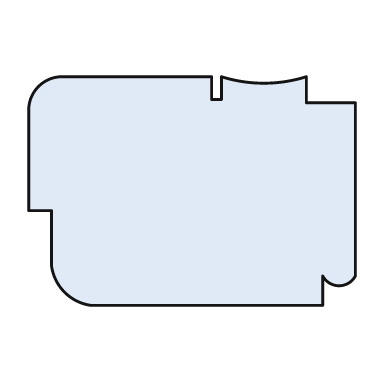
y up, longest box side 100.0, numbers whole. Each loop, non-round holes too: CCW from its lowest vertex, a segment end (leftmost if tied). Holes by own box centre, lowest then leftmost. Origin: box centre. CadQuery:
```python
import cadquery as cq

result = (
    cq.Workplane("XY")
    .moveTo(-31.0, -35.0)
    .lineTo(40.0, -35.0)
    .lineTo(40.0, -26.0)
    .threePointArc((45.0, -29.0), (50.0, -26.0))
    .lineTo(50.0, 27.0)
    .lineTo(35.0, 27.0)
    .lineTo(35.0, 35.0)
    .threePointArc((22.0, 33.0), (9.0, 35.0))
    .lineTo(9.0, 28.0)
    .lineTo(6.0, 28.0)
    .lineTo(6.0, 35.0)
    .lineTo(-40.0, 35.0)
    .threePointArc((-47.0, 32.0), (-50.0, 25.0))
    .lineTo(-50.0, -6.0)
    .lineTo(-43.0, -6.0)
    .lineTo(-43.0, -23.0)
    .threePointArc((-39.0, -31.0), (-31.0, -35.0))
    .close()
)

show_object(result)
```